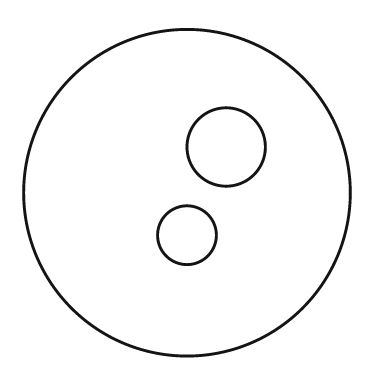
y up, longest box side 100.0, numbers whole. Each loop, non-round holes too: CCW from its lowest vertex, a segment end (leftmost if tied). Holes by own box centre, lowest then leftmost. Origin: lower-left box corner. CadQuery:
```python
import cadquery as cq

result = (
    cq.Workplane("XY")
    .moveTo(50.0, 50.0)
    .circle(50.0)
    .moveTo(50.0, 37.0)
    .circle(9.0)
    .moveTo(62.0, 64.0)
    .circle(12.0)
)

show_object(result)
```